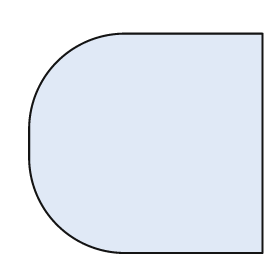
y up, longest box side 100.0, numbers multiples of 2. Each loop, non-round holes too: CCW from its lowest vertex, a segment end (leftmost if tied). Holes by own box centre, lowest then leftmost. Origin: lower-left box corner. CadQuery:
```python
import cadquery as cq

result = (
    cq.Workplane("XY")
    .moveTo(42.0, 0.0)
    .lineTo(100.0, 0.0)
    .lineTo(100.0, 94.0)
    .lineTo(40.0, 94.0)
    .threePointArc((12.0, 82.0), (0.0, 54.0))
    .lineTo(0.0, 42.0)
    .threePointArc((12.0, 12.0), (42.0, 0.0))
    .close()
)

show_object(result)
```